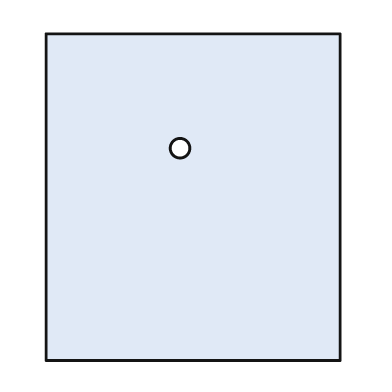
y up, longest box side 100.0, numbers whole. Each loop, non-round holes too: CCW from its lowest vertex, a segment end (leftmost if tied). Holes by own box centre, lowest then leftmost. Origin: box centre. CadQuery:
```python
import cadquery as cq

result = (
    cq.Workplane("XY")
    .moveTo(-45.0, -50.0)
    .lineTo(45.0, -50.0)
    .lineTo(45.0, 50.0)
    .lineTo(-45.0, 50.0)
    .close()
    .moveTo(-4.0, 15.0)
    .circle(3.0)
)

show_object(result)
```